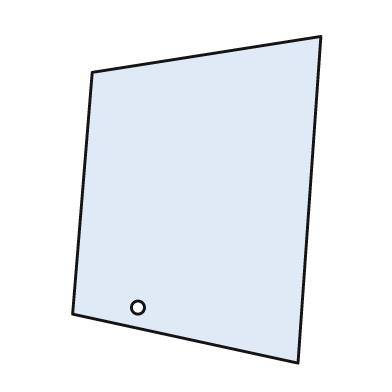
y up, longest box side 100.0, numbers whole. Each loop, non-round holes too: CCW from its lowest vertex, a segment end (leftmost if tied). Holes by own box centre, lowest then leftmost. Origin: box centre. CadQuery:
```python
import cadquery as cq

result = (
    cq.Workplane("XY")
    .moveTo(31.0, -50.0)
    .lineTo(38.0, 50.0)
    .lineTo(-32.0, 39.0)
    .lineTo(-38.0, -35.0)
    .close()
    .moveTo(-18.0, -33.0)
    .circle(2.0)
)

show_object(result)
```